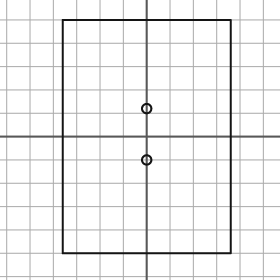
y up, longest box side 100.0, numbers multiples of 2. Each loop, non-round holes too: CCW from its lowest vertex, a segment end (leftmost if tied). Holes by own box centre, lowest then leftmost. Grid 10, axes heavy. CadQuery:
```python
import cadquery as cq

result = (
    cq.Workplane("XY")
    .moveTo(-36.0, -50.0)
    .lineTo(36.0, -50.0)
    .lineTo(36.0, 50.0)
    .lineTo(-36.0, 50.0)
    .close()
    .moveTo(0.0, -10.0)
    .circle(2.0)
    .moveTo(0.0, 12.0)
    .circle(2.0)
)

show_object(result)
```